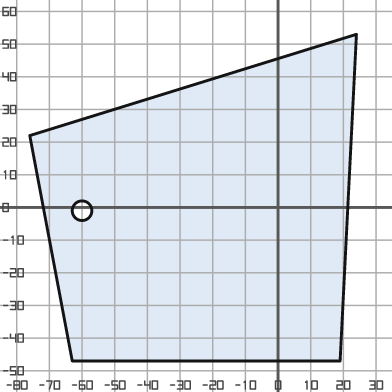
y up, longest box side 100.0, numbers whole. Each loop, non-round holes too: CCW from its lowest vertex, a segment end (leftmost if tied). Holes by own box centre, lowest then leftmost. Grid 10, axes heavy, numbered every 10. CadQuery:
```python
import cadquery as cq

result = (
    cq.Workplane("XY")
    .moveTo(-63.0, -47.0)
    .lineTo(19.0, -47.0)
    .lineTo(24.0, 53.0)
    .lineTo(-76.0, 22.0)
    .close()
    .moveTo(-60.0, -1.0)
    .circle(3.0)
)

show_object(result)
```